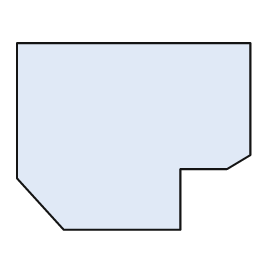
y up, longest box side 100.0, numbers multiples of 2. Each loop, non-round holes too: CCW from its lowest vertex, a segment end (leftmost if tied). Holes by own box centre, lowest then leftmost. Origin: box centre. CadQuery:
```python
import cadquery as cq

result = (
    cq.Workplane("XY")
    .moveTo(-30.0, -40.0)
    .lineTo(20.0, -40.0)
    .lineTo(20.0, -14.0)
    .lineTo(40.0, -14.0)
    .lineTo(50.0, -8.0)
    .lineTo(50.0, 40.0)
    .lineTo(-50.0, 40.0)
    .lineTo(-50.0, -18.0)
    .close()
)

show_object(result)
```